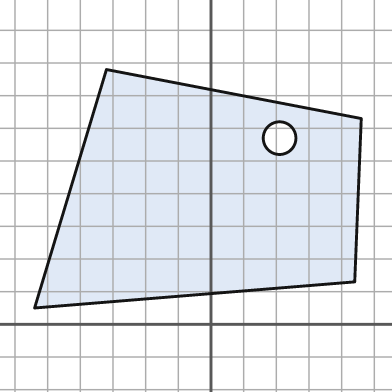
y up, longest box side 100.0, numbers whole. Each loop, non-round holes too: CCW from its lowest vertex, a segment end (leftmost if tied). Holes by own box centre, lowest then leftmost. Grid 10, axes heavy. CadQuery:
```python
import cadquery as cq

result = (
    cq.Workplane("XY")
    .moveTo(-54.0, 5.0)
    .lineTo(44.0, 13.0)
    .lineTo(46.0, 63.0)
    .lineTo(-32.0, 78.0)
    .close()
    .moveTo(21.0, 57.0)
    .circle(5.0)
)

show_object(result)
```